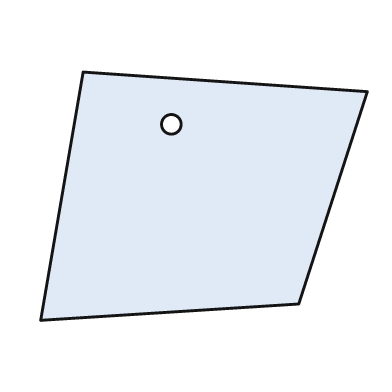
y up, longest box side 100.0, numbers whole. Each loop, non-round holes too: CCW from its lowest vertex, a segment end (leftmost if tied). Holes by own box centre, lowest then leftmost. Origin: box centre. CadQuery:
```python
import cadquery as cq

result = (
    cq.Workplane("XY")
    .moveTo(-50.0, -38.0)
    .lineTo(29.0, -33.0)
    .lineTo(50.0, 32.0)
    .lineTo(-37.0, 38.0)
    .close()
    .moveTo(-10.0, 22.0)
    .circle(3.0)
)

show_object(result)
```